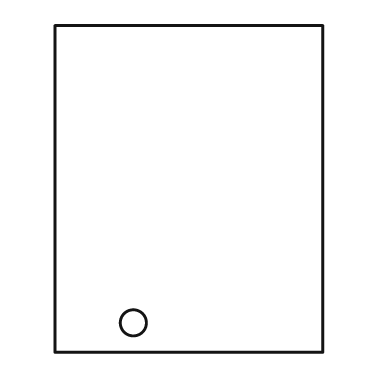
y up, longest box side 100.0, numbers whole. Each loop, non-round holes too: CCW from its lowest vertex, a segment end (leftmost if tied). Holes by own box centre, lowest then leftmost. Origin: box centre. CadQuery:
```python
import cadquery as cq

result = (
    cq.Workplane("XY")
    .moveTo(-41.0, -50.0)
    .lineTo(41.0, -50.0)
    .lineTo(41.0, 50.0)
    .lineTo(-41.0, 50.0)
    .close()
    .moveTo(-17.0, -41.0)
    .circle(4.0)
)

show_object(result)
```